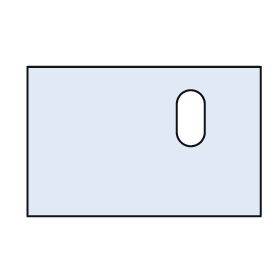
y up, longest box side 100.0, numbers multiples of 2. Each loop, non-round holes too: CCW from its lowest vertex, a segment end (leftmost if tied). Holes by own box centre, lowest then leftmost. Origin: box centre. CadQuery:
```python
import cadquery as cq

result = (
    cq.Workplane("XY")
    .moveTo(-50.0, -32.0)
    .lineTo(50.0, -32.0)
    .lineTo(50.0, 32.0)
    .lineTo(-50.0, 32.0)
    .close()
    .moveTo(14.0, 4.0)
    .threePointArc((20.0, -2.0), (26.0, 4.0))
    .lineTo(26.0, 16.0)
    .threePointArc((20.0, 22.0), (14.0, 16.0))
    .close()
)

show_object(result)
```